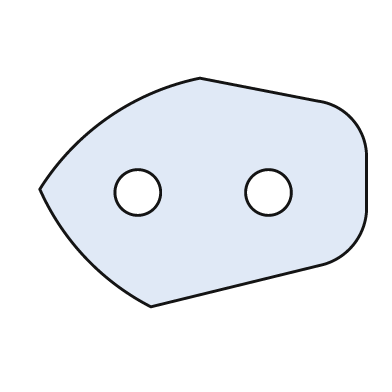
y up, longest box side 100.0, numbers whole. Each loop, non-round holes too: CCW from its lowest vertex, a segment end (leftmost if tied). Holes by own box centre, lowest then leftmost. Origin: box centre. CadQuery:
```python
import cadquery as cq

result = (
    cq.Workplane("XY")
    .moveTo(-16.0, -35.0)
    .lineTo(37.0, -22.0)
    .threePointArc((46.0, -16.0), (50.0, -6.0))
    .lineTo(50.0, 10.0)
    .threePointArc((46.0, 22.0), (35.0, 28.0))
    .lineTo(-1.0, 35.0)
    .threePointArc((-29.0, 23.0), (-50.0, 1.0))
    .threePointArc((-36.0, -20.0), (-16.0, -35.0))
    .close()
    .moveTo(-20.0, 0.0)
    .circle(7.0)
    .moveTo(20.0, 0.0)
    .circle(7.0)
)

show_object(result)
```